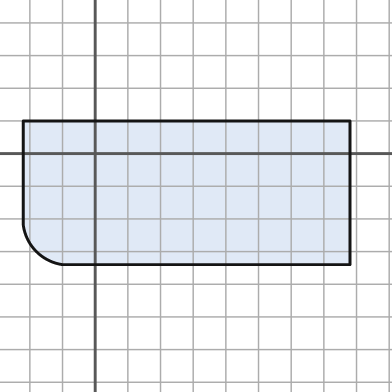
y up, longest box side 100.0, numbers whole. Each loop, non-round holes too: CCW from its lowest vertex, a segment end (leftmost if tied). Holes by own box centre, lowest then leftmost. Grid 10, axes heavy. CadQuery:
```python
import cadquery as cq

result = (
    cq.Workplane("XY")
    .moveTo(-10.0, -34.0)
    .lineTo(78.0, -34.0)
    .lineTo(78.0, 10.0)
    .lineTo(-22.0, 10.0)
    .lineTo(-22.0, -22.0)
    .threePointArc((-18.0, -30.0), (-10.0, -34.0))
    .close()
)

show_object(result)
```